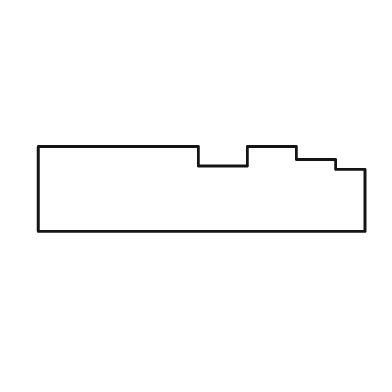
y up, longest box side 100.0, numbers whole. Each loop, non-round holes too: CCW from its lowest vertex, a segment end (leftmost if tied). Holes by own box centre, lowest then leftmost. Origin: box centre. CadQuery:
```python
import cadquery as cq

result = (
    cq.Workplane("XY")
    .moveTo(-50.0, -13.0)
    .lineTo(50.0, -13.0)
    .lineTo(50.0, 6.0)
    .lineTo(41.0, 6.0)
    .lineTo(41.0, 9.0)
    .lineTo(29.0, 9.0)
    .lineTo(29.0, 13.0)
    .lineTo(14.0, 13.0)
    .lineTo(14.0, 7.0)
    .lineTo(-1.0, 7.0)
    .lineTo(-1.0, 13.0)
    .lineTo(-50.0, 13.0)
    .close()
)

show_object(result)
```